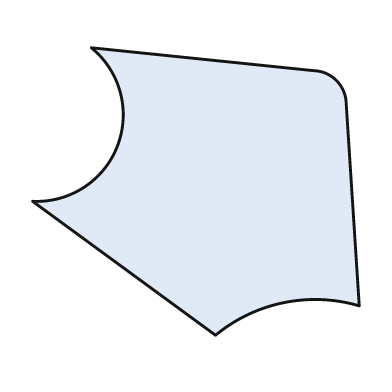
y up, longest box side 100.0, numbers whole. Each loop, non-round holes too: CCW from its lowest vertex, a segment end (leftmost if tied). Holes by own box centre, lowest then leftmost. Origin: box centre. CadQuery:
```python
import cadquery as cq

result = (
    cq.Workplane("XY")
    .moveTo(6.0, -44.0)
    .threePointArc((27.0, -34.0), (50.0, -35.0))
    .lineTo(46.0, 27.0)
    .threePointArc((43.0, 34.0), (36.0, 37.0))
    .lineTo(-32.0, 44.0)
    .threePointArc((-24.0, 14.0), (-50.0, -3.0))
    .close()
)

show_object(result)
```